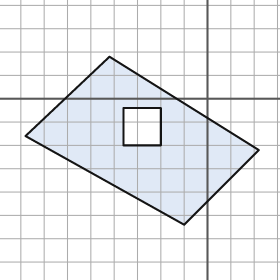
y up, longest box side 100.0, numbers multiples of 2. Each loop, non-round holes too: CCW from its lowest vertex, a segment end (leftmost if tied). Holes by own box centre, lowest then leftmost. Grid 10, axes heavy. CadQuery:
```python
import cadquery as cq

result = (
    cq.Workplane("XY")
    .moveTo(-10.0, -54.0)
    .lineTo(22.0, -22.0)
    .lineTo(-42.0, 18.0)
    .lineTo(-78.0, -16.0)
    .close()
    .moveTo(-36.0, -20.0)
    .lineTo(-20.0, -20.0)
    .lineTo(-20.0, -4.0)
    .lineTo(-36.0, -4.0)
    .close()
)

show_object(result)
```